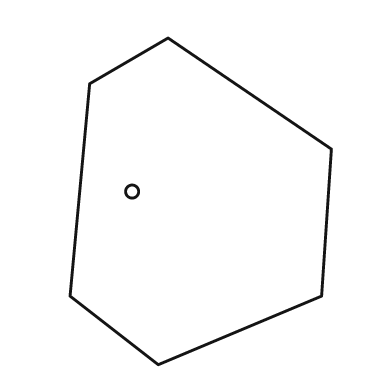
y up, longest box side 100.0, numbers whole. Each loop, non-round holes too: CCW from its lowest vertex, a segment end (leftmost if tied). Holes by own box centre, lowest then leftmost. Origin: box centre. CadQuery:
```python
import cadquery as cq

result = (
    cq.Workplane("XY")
    .moveTo(-13.0, -50.0)
    .lineTo(37.0, -29.0)
    .lineTo(40.0, 16.0)
    .lineTo(-10.0, 50.0)
    .lineTo(-34.0, 36.0)
    .lineTo(-40.0, -29.0)
    .close()
    .moveTo(-21.0, 3.0)
    .circle(2.0)
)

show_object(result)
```